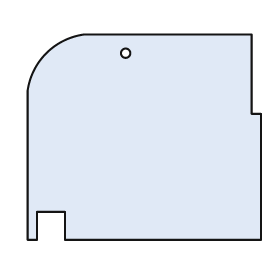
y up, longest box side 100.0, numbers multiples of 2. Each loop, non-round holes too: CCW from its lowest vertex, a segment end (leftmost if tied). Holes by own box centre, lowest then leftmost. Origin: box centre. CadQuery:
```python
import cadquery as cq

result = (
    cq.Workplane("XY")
    .moveTo(-50.0, -44.0)
    .lineTo(-46.0, -44.0)
    .lineTo(-46.0, -32.0)
    .lineTo(-34.0, -32.0)
    .lineTo(-34.0, -44.0)
    .lineTo(50.0, -44.0)
    .lineTo(50.0, 10.0)
    .lineTo(46.0, 10.0)
    .lineTo(46.0, 44.0)
    .lineTo(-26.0, 44.0)
    .threePointArc((-42.0, 36.0), (-50.0, 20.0))
    .close()
    .moveTo(-8.0, 36.0)
    .circle(2.0)
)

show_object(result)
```